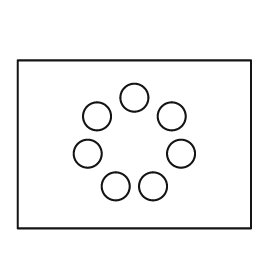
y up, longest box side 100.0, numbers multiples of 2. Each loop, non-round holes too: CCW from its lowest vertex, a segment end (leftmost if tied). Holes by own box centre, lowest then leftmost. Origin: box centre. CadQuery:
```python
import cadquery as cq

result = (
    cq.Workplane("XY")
    .moveTo(-50.0, -36.0)
    .lineTo(50.0, -36.0)
    .lineTo(50.0, 36.0)
    .lineTo(-50.0, 36.0)
    .close()
    .moveTo(-8.0, -18.0)
    .circle(6.0)
    .moveTo(8.0, -18.0)
    .circle(6.0)
    .moveTo(-20.0, -4.0)
    .circle(6.0)
    .moveTo(20.0, -4.0)
    .circle(6.0)
    .moveTo(-16.0, 12.0)
    .circle(6.0)
    .moveTo(16.0, 12.0)
    .circle(6.0)
    .moveTo(0.0, 20.0)
    .circle(6.0)
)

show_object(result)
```